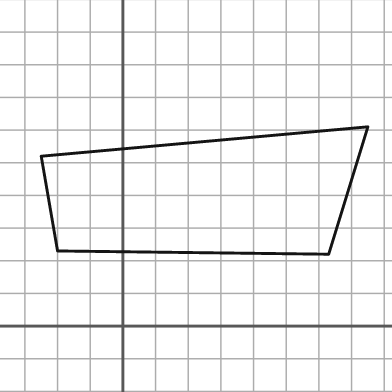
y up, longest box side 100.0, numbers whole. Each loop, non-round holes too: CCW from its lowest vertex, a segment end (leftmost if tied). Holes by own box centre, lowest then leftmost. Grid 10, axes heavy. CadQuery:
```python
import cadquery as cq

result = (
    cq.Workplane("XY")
    .moveTo(63.0, 22.0)
    .lineTo(75.0, 61.0)
    .lineTo(-25.0, 52.0)
    .lineTo(-20.0, 23.0)
    .close()
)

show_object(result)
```